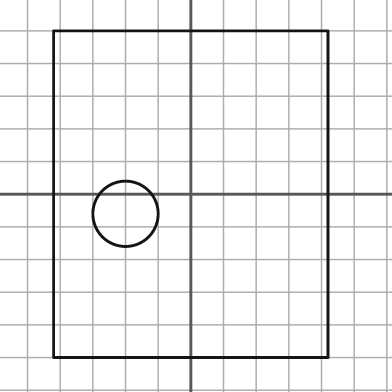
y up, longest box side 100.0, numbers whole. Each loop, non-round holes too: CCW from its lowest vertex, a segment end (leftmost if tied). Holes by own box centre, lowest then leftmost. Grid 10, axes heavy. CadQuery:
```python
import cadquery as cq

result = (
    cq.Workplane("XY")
    .moveTo(-42.0, -50.0)
    .lineTo(42.0, -50.0)
    .lineTo(42.0, 50.0)
    .lineTo(-42.0, 50.0)
    .close()
    .moveTo(-20.0, -6.0)
    .circle(10.0)
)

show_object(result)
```